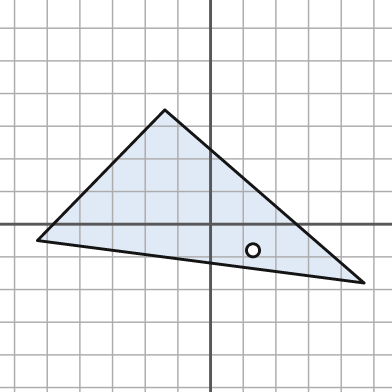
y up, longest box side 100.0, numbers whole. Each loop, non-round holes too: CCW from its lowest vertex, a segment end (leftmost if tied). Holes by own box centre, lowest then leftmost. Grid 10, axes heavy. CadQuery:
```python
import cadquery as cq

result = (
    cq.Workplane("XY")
    .moveTo(47.0, -18.0)
    .lineTo(-14.0, 35.0)
    .lineTo(-53.0, -5.0)
    .close()
    .moveTo(13.0, -8.0)
    .circle(2.0)
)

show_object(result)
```